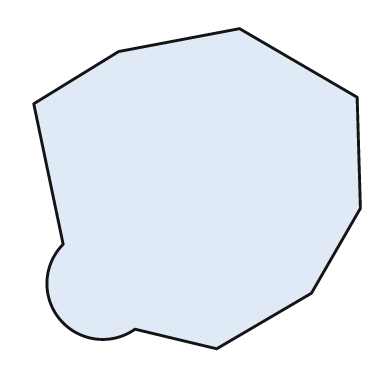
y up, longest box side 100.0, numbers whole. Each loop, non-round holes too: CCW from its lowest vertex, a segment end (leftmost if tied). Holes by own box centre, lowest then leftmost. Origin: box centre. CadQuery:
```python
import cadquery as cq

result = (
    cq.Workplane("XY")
    .moveTo(6.0, -49.0)
    .lineTo(35.0, -32.0)
    .lineTo(50.0, -6.0)
    .lineTo(49.0, 28.0)
    .lineTo(13.0, 49.0)
    .lineTo(-24.0, 42.0)
    .lineTo(-50.0, 26.0)
    .lineTo(-41.0, -17.0)
    .threePointArc((-42.0, -40.0), (-19.0, -43.0))
    .close()
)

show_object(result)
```